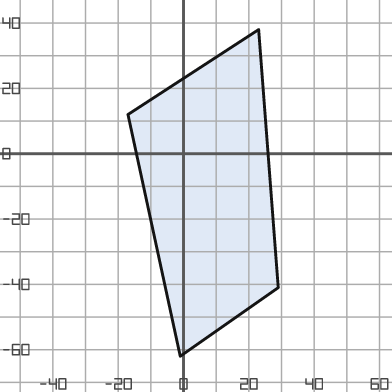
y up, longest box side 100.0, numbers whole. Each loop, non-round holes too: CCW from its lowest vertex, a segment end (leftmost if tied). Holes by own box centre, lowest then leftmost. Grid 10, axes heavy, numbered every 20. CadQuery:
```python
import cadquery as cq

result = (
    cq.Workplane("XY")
    .moveTo(-1.0, -62.0)
    .lineTo(29.0, -41.0)
    .lineTo(23.0, 38.0)
    .lineTo(-17.0, 12.0)
    .close()
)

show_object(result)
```